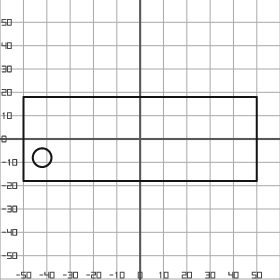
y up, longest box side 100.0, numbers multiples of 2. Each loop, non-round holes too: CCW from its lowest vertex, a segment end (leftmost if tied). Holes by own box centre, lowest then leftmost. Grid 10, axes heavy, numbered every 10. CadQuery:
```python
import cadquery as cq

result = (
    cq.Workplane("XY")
    .moveTo(-50.0, -18.0)
    .lineTo(50.0, -18.0)
    .lineTo(50.0, 18.0)
    .lineTo(-50.0, 18.0)
    .close()
    .moveTo(-42.0, -8.0)
    .circle(4.0)
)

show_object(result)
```